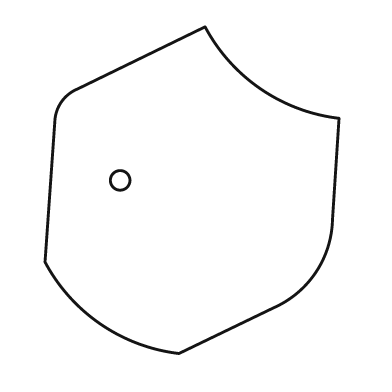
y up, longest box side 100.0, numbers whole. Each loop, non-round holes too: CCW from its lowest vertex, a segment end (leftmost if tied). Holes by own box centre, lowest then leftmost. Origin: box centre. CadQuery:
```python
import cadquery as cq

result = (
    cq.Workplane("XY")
    .moveTo(-4.0, -50.0)
    .lineTo(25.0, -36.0)
    .threePointArc((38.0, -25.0), (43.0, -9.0))
    .lineTo(45.0, 22.0)
    .threePointArc((21.0, 31.0), (4.0, 50.0))
    .lineTo(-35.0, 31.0)
    .threePointArc((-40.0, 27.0), (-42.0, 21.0))
    .lineTo(-45.0, -22.0)
    .threePointArc((-28.0, -41.0), (-4.0, -50.0))
    .close()
    .moveTo(-22.0, 3.0)
    .circle(3.0)
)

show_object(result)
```